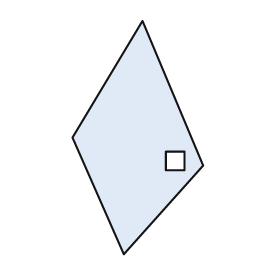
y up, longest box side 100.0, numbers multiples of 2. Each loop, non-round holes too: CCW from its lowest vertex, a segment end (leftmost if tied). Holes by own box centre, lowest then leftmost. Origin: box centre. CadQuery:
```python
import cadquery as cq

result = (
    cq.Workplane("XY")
    .moveTo(-6.0, -50.0)
    .lineTo(28.0, -12.0)
    .lineTo(2.0, 50.0)
    .lineTo(-28.0, 0.0)
    .close()
    .moveTo(12.0, -14.0)
    .lineTo(20.0, -14.0)
    .lineTo(20.0, -6.0)
    .lineTo(12.0, -6.0)
    .close()
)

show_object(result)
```